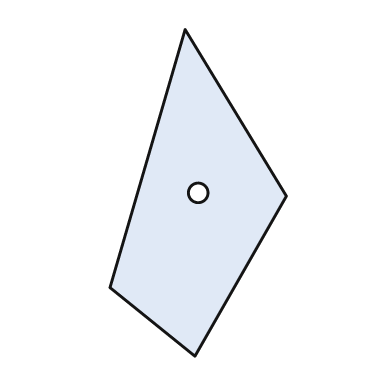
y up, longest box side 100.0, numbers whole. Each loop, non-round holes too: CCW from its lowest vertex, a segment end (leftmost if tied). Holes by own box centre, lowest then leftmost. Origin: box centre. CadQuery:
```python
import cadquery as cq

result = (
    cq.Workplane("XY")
    .moveTo(-1.0, -50.0)
    .lineTo(27.0, -1.0)
    .lineTo(-4.0, 50.0)
    .lineTo(-27.0, -29.0)
    .close()
    .moveTo(0.0, 0.0)
    .circle(3.0)
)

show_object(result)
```